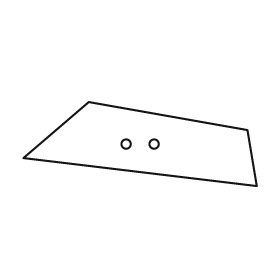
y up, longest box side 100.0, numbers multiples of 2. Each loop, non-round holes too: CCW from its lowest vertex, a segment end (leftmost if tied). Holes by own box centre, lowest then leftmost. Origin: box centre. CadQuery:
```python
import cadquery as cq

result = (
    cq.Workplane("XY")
    .moveTo(50.0, -18.0)
    .lineTo(46.0, 6.0)
    .lineTo(-22.0, 18.0)
    .lineTo(-50.0, -6.0)
    .close()
    .moveTo(-6.0, 0.0)
    .circle(2.0)
    .moveTo(6.0, 0.0)
    .circle(2.0)
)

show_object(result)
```